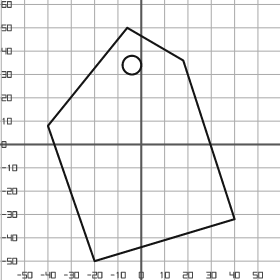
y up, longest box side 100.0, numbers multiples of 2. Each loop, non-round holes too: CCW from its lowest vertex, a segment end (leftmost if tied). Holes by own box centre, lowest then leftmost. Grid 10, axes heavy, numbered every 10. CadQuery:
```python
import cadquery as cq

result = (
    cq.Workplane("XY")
    .moveTo(-20.0, -50.0)
    .lineTo(40.0, -32.0)
    .lineTo(18.0, 36.0)
    .lineTo(-6.0, 50.0)
    .lineTo(-40.0, 8.0)
    .close()
    .moveTo(-4.0, 34.0)
    .circle(4.0)
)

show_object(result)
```